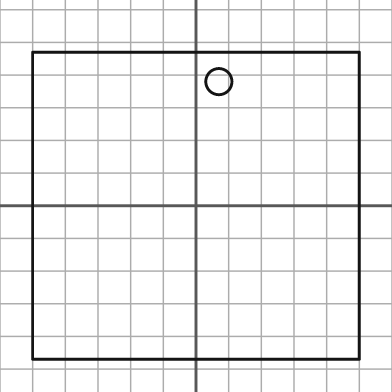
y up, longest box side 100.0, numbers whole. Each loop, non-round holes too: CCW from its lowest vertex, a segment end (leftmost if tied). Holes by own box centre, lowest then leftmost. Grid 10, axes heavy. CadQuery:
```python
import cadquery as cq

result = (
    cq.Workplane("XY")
    .moveTo(-50.0, -47.0)
    .lineTo(50.0, -47.0)
    .lineTo(50.0, 47.0)
    .lineTo(-50.0, 47.0)
    .close()
    .moveTo(7.0, 38.0)
    .circle(4.0)
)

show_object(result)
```